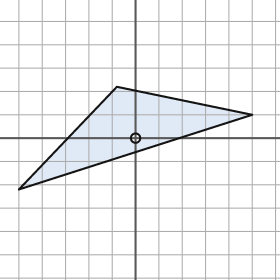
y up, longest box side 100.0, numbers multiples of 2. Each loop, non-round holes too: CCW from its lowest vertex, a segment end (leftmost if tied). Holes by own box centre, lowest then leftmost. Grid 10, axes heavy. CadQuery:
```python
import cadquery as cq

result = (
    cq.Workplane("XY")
    .moveTo(-50.0, -22.0)
    .lineTo(50.0, 10.0)
    .lineTo(-8.0, 22.0)
    .close()
    .moveTo(0.0, 0.0)
    .circle(2.0)
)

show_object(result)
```